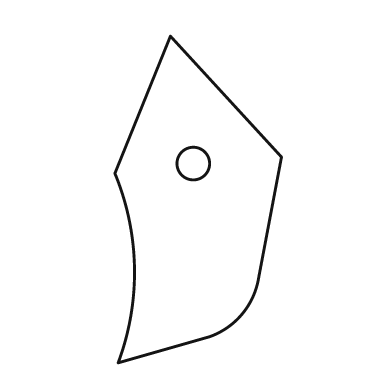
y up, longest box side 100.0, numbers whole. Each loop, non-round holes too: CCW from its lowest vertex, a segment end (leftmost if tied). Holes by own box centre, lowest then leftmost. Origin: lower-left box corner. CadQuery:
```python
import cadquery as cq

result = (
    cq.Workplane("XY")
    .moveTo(1.0, 0.0)
    .lineTo(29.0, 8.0)
    .threePointArc((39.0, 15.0), (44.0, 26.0))
    .lineTo(51.0, 63.0)
    .lineTo(17.0, 100.0)
    .lineTo(0.0, 58.0)
    .threePointArc((6.0, 29.0), (1.0, 0.0))
    .close()
    .moveTo(24.0, 61.0)
    .circle(5.0)
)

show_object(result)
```